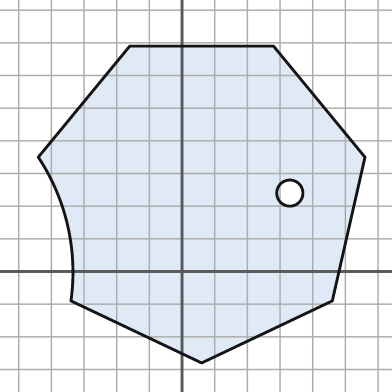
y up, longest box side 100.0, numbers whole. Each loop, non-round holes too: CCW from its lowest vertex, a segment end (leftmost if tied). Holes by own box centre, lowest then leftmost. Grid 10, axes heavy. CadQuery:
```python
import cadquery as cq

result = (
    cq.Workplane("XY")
    .moveTo(6.0, -28.0)
    .lineTo(46.0, -9.0)
    .lineTo(56.0, 35.0)
    .lineTo(28.0, 69.0)
    .lineTo(-16.0, 69.0)
    .lineTo(-44.0, 35.0)
    .threePointArc((-35.0, 14.0), (-34.0, -9.0))
    .close()
    .moveTo(33.0, 24.0)
    .circle(4.0)
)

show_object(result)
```